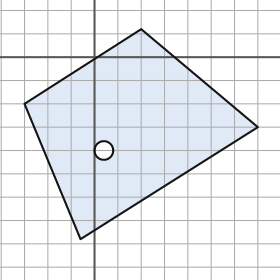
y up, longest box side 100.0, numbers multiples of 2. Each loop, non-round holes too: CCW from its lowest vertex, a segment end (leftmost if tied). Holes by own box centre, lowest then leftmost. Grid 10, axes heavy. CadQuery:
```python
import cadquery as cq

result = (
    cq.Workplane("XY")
    .moveTo(-6.0, -78.0)
    .lineTo(70.0, -30.0)
    .lineTo(20.0, 12.0)
    .lineTo(-30.0, -20.0)
    .close()
    .moveTo(4.0, -40.0)
    .circle(4.0)
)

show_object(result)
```